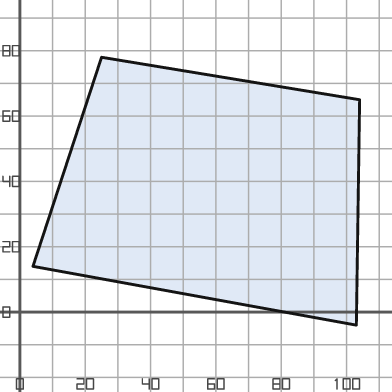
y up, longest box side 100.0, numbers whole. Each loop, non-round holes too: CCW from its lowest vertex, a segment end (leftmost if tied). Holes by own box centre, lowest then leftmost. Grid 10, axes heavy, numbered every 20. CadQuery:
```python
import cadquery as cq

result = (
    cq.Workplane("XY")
    .moveTo(103.0, -4.0)
    .lineTo(104.0, 65.0)
    .lineTo(25.0, 78.0)
    .lineTo(4.0, 14.0)
    .close()
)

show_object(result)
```